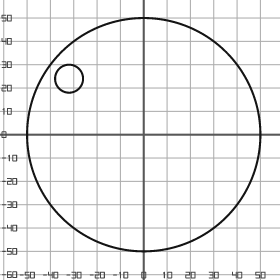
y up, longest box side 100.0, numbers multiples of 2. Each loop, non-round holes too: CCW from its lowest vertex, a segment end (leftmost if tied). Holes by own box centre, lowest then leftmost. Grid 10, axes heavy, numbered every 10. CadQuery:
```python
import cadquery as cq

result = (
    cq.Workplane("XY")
    .moveTo(0.0, 0.0)
    .circle(50.0)
    .moveTo(-32.0, 24.0)
    .circle(6.0)
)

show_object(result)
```